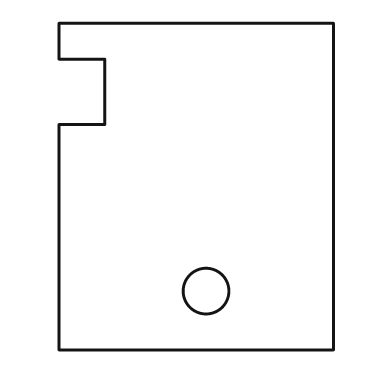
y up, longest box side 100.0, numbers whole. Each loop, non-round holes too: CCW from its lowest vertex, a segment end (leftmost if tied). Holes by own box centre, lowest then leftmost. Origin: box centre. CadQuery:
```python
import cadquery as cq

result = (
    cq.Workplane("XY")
    .moveTo(-42.0, -50.0)
    .lineTo(42.0, -50.0)
    .lineTo(42.0, 50.0)
    .lineTo(-42.0, 50.0)
    .lineTo(-42.0, 39.0)
    .lineTo(-28.0, 39.0)
    .lineTo(-28.0, 19.0)
    .lineTo(-42.0, 19.0)
    .close()
    .moveTo(3.0, -32.0)
    .circle(7.0)
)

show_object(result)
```